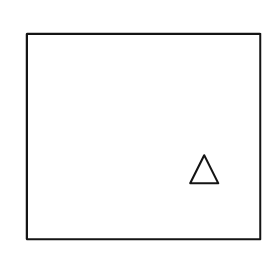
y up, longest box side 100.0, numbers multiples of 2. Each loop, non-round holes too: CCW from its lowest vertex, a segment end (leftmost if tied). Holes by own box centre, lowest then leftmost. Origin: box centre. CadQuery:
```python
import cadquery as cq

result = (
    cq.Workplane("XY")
    .moveTo(-50.0, -44.0)
    .lineTo(50.0, -44.0)
    .lineTo(50.0, 44.0)
    .lineTo(-50.0, 44.0)
    .close()
    .moveTo(20.0, -20.0)
    .lineTo(32.0, -20.0)
    .lineTo(26.0, -8.0)
    .close()
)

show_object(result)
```